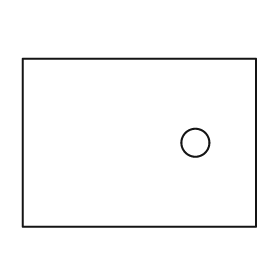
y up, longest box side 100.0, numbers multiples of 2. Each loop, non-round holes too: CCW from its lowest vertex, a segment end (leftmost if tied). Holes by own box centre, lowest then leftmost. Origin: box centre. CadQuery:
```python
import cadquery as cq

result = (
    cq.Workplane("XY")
    .moveTo(-50.0, -36.0)
    .lineTo(50.0, -36.0)
    .lineTo(50.0, 36.0)
    .lineTo(-50.0, 36.0)
    .close()
    .moveTo(24.0, 0.0)
    .circle(6.0)
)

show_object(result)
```